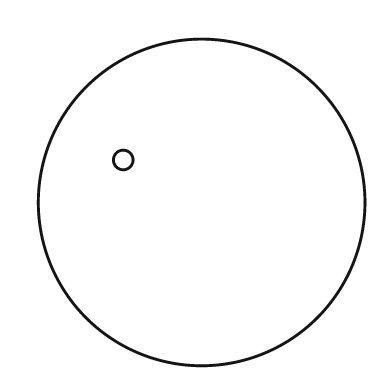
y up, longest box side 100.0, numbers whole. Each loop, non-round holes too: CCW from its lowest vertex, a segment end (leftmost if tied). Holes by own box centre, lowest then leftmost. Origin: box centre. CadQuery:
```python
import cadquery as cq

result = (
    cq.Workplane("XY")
    .moveTo(0.0, 0.0)
    .circle(50.0)
    .moveTo(-24.0, 13.0)
    .circle(3.0)
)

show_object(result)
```